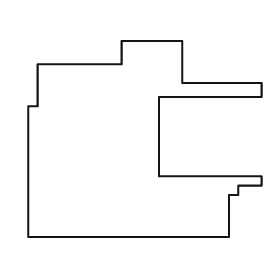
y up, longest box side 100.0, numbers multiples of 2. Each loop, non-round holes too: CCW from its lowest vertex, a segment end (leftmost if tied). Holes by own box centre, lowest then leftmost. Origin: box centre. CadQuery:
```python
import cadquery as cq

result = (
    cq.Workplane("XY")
    .moveTo(-50.0, -42.0)
    .lineTo(36.0, -42.0)
    .lineTo(36.0, -24.0)
    .lineTo(40.0, -24.0)
    .lineTo(40.0, -20.0)
    .lineTo(50.0, -20.0)
    .lineTo(50.0, -16.0)
    .lineTo(6.0, -16.0)
    .lineTo(6.0, 18.0)
    .lineTo(50.0, 18.0)
    .lineTo(50.0, 24.0)
    .lineTo(16.0, 24.0)
    .lineTo(16.0, 42.0)
    .lineTo(-10.0, 42.0)
    .lineTo(-10.0, 32.0)
    .lineTo(-46.0, 32.0)
    .lineTo(-46.0, 14.0)
    .lineTo(-50.0, 14.0)
    .close()
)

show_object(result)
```